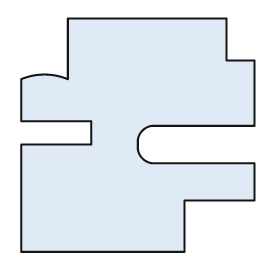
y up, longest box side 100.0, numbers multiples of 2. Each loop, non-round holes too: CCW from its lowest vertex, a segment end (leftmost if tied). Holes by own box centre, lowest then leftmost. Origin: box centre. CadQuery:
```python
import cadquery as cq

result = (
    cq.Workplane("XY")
    .moveTo(-50.0, -50.0)
    .lineTo(20.0, -50.0)
    .lineTo(20.0, -28.0)
    .lineTo(50.0, -28.0)
    .lineTo(50.0, -12.0)
    .lineTo(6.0, -12.0)
    .threePointArc((2.0, -10.0), (0.0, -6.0))
    .lineTo(0.0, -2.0)
    .threePointArc((2.0, 2.0), (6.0, 4.0))
    .lineTo(50.0, 4.0)
    .lineTo(50.0, 32.0)
    .lineTo(38.0, 32.0)
    .lineTo(38.0, 50.0)
    .lineTo(-30.0, 50.0)
    .lineTo(-30.0, 24.0)
    .threePointArc((-40.0, 26.0), (-50.0, 24.0))
    .lineTo(-50.0, 6.0)
    .lineTo(-20.0, 6.0)
    .lineTo(-20.0, -4.0)
    .lineTo(-50.0, -4.0)
    .close()
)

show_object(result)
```